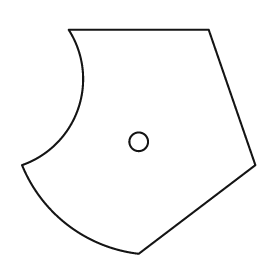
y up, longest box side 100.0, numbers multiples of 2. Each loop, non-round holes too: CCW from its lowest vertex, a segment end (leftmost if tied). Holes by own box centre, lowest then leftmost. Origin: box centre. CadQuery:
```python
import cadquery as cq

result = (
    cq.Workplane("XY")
    .moveTo(0.0, -48.0)
    .lineTo(50.0, -10.0)
    .lineTo(30.0, 48.0)
    .lineTo(-30.0, 48.0)
    .threePointArc((-26.0, 14.0), (-50.0, -10.0))
    .threePointArc((-30.0, -36.0), (0.0, -48.0))
    .close()
    .moveTo(0.0, 0.0)
    .circle(4.0)
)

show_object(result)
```